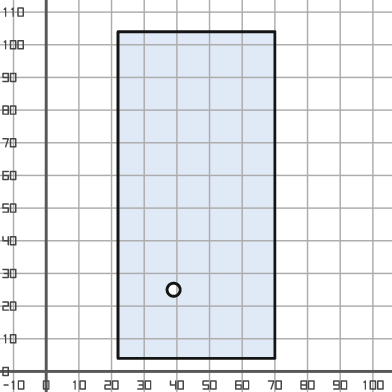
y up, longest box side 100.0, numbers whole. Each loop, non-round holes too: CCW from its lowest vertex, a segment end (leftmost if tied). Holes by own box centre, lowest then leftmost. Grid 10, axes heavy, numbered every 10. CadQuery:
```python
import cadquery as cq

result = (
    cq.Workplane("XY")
    .moveTo(22.0, 4.0)
    .lineTo(70.0, 4.0)
    .lineTo(70.0, 104.0)
    .lineTo(22.0, 104.0)
    .close()
    .moveTo(39.0, 25.0)
    .circle(2.0)
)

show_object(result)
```